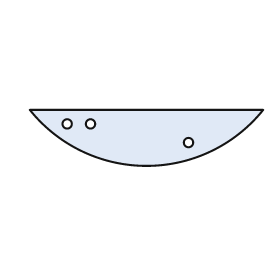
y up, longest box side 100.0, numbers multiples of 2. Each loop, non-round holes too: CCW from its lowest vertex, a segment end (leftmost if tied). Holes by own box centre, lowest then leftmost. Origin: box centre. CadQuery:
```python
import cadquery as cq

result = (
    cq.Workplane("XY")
    .moveTo(-50.0, 12.0)
    .threePointArc((0.0, -12.0), (50.0, 12.0))
    .close()
    .moveTo(18.0, -2.0)
    .circle(2.0)
    .moveTo(-34.0, 6.0)
    .circle(2.0)
    .moveTo(-24.0, 6.0)
    .circle(2.0)
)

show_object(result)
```